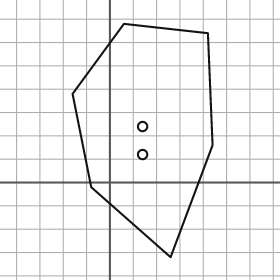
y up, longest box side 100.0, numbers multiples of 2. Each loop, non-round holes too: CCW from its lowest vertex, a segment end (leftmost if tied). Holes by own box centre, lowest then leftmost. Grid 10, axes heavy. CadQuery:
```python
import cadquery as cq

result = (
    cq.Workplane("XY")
    .moveTo(26.0, -32.0)
    .lineTo(44.0, 16.0)
    .lineTo(42.0, 64.0)
    .lineTo(6.0, 68.0)
    .lineTo(-16.0, 38.0)
    .lineTo(-8.0, -2.0)
    .close()
    .moveTo(14.0, 12.0)
    .circle(2.0)
    .moveTo(14.0, 24.0)
    .circle(2.0)
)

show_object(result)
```